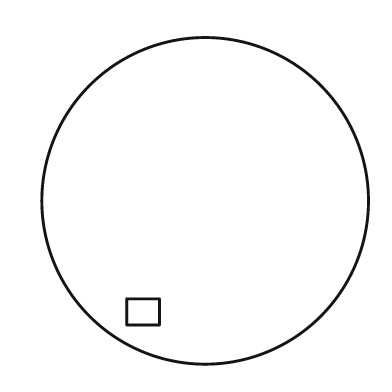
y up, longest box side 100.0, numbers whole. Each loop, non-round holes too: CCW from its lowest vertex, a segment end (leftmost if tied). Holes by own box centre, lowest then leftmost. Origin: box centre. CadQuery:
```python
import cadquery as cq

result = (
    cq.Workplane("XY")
    .moveTo(0.0, 0.0)
    .circle(50.0)
    .moveTo(-24.0, -38.0)
    .lineTo(-14.0, -38.0)
    .lineTo(-14.0, -30.0)
    .lineTo(-24.0, -30.0)
    .close()
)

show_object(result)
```